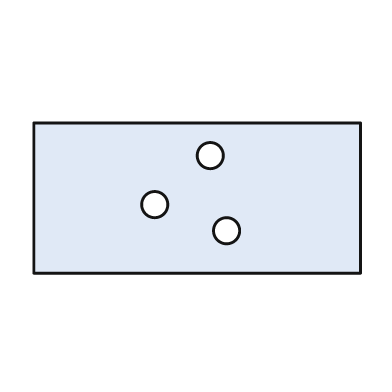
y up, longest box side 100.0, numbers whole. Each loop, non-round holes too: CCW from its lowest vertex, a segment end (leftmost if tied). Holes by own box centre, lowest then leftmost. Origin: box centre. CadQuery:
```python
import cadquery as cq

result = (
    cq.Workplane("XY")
    .moveTo(-50.0, -23.0)
    .lineTo(50.0, -23.0)
    .lineTo(50.0, 23.0)
    .lineTo(-50.0, 23.0)
    .close()
    .moveTo(9.0, -10.0)
    .circle(4.0)
    .moveTo(-13.0, -2.0)
    .circle(4.0)
    .moveTo(4.0, 13.0)
    .circle(4.0)
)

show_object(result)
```